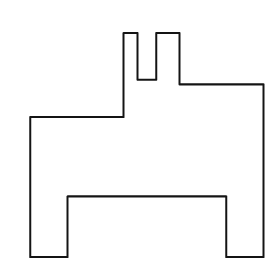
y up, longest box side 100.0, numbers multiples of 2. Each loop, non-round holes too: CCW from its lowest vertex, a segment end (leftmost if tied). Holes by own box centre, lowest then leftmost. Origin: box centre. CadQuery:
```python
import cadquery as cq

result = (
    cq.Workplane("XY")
    .moveTo(-50.0, -48.0)
    .lineTo(-34.0, -48.0)
    .lineTo(-34.0, -22.0)
    .lineTo(34.0, -22.0)
    .lineTo(34.0, -48.0)
    .lineTo(50.0, -48.0)
    .lineTo(50.0, 26.0)
    .lineTo(14.0, 26.0)
    .lineTo(14.0, 48.0)
    .lineTo(4.0, 48.0)
    .lineTo(4.0, 28.0)
    .lineTo(-4.0, 28.0)
    .lineTo(-4.0, 48.0)
    .lineTo(-10.0, 48.0)
    .lineTo(-10.0, 12.0)
    .lineTo(-50.0, 12.0)
    .close()
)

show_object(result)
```